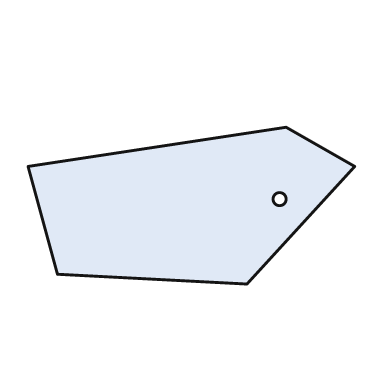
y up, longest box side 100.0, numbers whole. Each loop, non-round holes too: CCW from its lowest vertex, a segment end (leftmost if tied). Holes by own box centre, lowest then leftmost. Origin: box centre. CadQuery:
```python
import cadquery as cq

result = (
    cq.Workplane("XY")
    .moveTo(17.0, -24.0)
    .lineTo(50.0, 12.0)
    .lineTo(29.0, 24.0)
    .lineTo(-50.0, 12.0)
    .lineTo(-41.0, -21.0)
    .close()
    .moveTo(27.0, 2.0)
    .circle(2.0)
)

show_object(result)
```